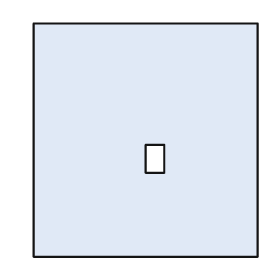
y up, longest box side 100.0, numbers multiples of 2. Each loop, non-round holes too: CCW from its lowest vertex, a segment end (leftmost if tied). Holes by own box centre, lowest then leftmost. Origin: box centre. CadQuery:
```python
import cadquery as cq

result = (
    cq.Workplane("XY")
    .moveTo(-48.0, -50.0)
    .lineTo(48.0, -50.0)
    .lineTo(48.0, 50.0)
    .lineTo(-48.0, 50.0)
    .close()
    .moveTo(0.0, -14.0)
    .lineTo(8.0, -14.0)
    .lineTo(8.0, -2.0)
    .lineTo(0.0, -2.0)
    .close()
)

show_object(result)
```